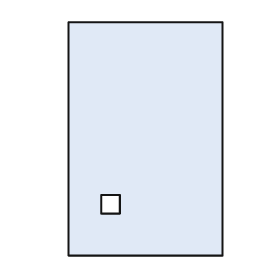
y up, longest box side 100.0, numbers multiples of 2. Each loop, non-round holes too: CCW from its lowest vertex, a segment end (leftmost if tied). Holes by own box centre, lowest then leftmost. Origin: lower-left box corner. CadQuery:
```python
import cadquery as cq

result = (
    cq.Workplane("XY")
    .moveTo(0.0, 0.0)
    .lineTo(66.0, 0.0)
    .lineTo(66.0, 100.0)
    .lineTo(0.0, 100.0)
    .close()
    .moveTo(14.0, 18.0)
    .lineTo(22.0, 18.0)
    .lineTo(22.0, 26.0)
    .lineTo(14.0, 26.0)
    .close()
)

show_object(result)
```